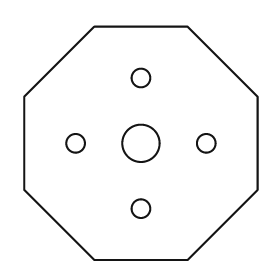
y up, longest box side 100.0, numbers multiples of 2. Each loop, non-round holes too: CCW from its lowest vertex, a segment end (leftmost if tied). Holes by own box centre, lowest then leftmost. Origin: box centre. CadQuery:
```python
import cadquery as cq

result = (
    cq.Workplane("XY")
    .moveTo(-20.0, -50.0)
    .lineTo(20.0, -50.0)
    .lineTo(50.0, -20.0)
    .lineTo(50.0, 20.0)
    .lineTo(20.0, 50.0)
    .lineTo(-20.0, 50.0)
    .lineTo(-50.0, 20.0)
    .lineTo(-50.0, -20.0)
    .close()
    .moveTo(0.0, -28.0)
    .circle(4.0)
    .moveTo(-28.0, 0.0)
    .circle(4.0)
    .moveTo(0.0, 0.0)
    .circle(8.0)
    .moveTo(28.0, 0.0)
    .circle(4.0)
    .moveTo(0.0, 28.0)
    .circle(4.0)
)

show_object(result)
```